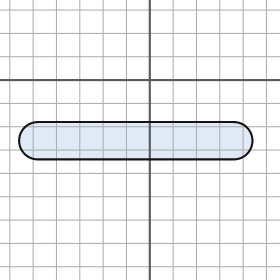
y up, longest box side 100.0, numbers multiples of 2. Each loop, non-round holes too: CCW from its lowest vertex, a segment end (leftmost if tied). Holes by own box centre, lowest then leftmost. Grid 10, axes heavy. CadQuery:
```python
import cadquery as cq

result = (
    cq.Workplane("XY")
    .moveTo(-48.0, -34.0)
    .lineTo(36.0, -34.0)
    .threePointArc((44.0, -26.0), (36.0, -18.0))
    .lineTo(-48.0, -18.0)
    .threePointArc((-56.0, -26.0), (-48.0, -34.0))
    .close()
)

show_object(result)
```